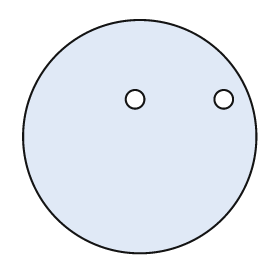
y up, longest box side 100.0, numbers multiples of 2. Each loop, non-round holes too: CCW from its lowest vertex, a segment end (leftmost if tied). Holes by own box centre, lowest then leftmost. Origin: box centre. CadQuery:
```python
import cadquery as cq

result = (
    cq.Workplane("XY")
    .moveTo(0.0, 0.0)
    .circle(50.0)
    .moveTo(-2.0, 16.0)
    .circle(4.0)
    .moveTo(36.0, 16.0)
    .circle(4.0)
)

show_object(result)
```